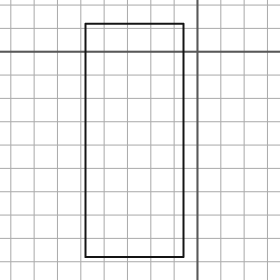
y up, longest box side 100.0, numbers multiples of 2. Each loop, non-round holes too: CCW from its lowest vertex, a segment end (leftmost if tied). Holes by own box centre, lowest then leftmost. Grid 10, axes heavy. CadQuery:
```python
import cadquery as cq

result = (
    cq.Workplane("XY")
    .moveTo(-48.0, -88.0)
    .lineTo(-6.0, -88.0)
    .lineTo(-6.0, 12.0)
    .lineTo(-48.0, 12.0)
    .close()
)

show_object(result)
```